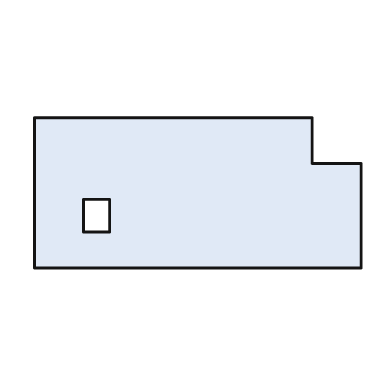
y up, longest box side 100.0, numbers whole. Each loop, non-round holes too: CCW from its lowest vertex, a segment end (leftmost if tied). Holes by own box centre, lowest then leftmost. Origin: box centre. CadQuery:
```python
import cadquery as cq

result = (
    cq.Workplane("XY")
    .moveTo(-50.0, -23.0)
    .lineTo(50.0, -23.0)
    .lineTo(50.0, 9.0)
    .lineTo(35.0, 9.0)
    .lineTo(35.0, 23.0)
    .lineTo(-50.0, 23.0)
    .close()
    .moveTo(-35.0, -12.0)
    .lineTo(-27.0, -12.0)
    .lineTo(-27.0, -2.0)
    .lineTo(-35.0, -2.0)
    .close()
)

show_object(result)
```